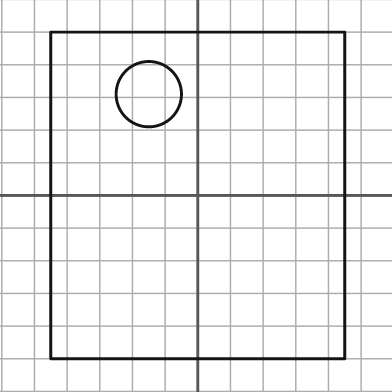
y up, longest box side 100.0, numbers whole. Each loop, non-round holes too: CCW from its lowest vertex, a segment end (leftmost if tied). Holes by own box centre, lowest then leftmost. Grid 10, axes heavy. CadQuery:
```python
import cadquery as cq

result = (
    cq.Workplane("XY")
    .moveTo(-45.0, -50.0)
    .lineTo(45.0, -50.0)
    .lineTo(45.0, 50.0)
    .lineTo(-45.0, 50.0)
    .close()
    .moveTo(-15.0, 31.0)
    .circle(10.0)
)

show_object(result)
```